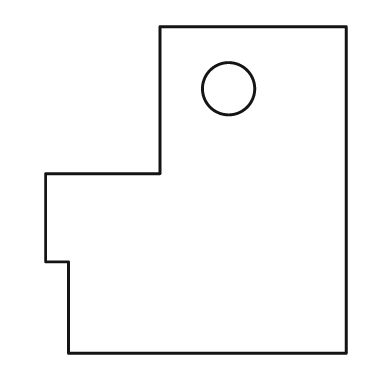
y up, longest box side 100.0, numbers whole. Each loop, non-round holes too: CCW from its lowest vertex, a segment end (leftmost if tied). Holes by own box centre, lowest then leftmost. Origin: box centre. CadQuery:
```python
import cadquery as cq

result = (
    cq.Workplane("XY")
    .moveTo(-39.0, -50.0)
    .lineTo(46.0, -50.0)
    .lineTo(46.0, 50.0)
    .lineTo(-11.0, 50.0)
    .lineTo(-11.0, 5.0)
    .lineTo(-46.0, 5.0)
    .lineTo(-46.0, -22.0)
    .lineTo(-39.0, -22.0)
    .close()
    .moveTo(10.0, 31.0)
    .circle(8.0)
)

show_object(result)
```